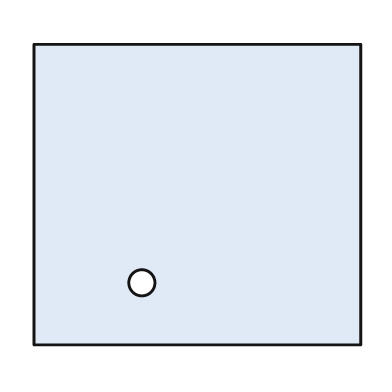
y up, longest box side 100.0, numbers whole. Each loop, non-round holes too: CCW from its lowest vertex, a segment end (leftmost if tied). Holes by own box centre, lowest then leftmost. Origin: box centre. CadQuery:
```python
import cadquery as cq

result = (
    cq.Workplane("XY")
    .moveTo(-50.0, -46.0)
    .lineTo(50.0, -46.0)
    .lineTo(50.0, 46.0)
    .lineTo(-50.0, 46.0)
    .close()
    .moveTo(-17.0, -27.0)
    .circle(4.0)
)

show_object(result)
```